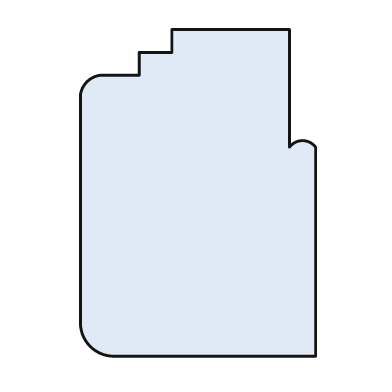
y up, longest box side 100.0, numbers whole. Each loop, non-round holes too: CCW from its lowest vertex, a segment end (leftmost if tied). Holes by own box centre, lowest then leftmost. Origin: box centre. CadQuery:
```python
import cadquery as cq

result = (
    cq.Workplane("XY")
    .moveTo(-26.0, -50.0)
    .lineTo(36.0, -50.0)
    .lineTo(36.0, 14.0)
    .threePointArc((32.0, 16.0), (28.0, 14.0))
    .lineTo(28.0, 50.0)
    .lineTo(-8.0, 50.0)
    .lineTo(-8.0, 43.0)
    .lineTo(-18.0, 43.0)
    .lineTo(-18.0, 36.0)
    .lineTo(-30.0, 36.0)
    .threePointArc((-34.0, 34.0), (-36.0, 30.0))
    .lineTo(-36.0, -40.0)
    .threePointArc((-33.0, -47.0), (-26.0, -50.0))
    .close()
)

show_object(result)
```